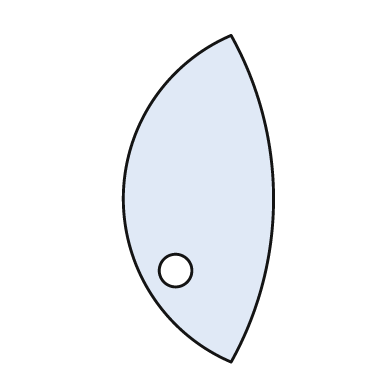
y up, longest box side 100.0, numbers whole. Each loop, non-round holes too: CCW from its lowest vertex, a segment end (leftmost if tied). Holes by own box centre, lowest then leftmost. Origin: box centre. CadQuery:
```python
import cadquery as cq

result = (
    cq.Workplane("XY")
    .moveTo(10.0, -50.0)
    .threePointArc((23.0, 0.0), (10.0, 50.0))
    .threePointArc((-23.0, 0.0), (10.0, -50.0))
    .close()
    .moveTo(-7.0, -22.0)
    .circle(5.0)
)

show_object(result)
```